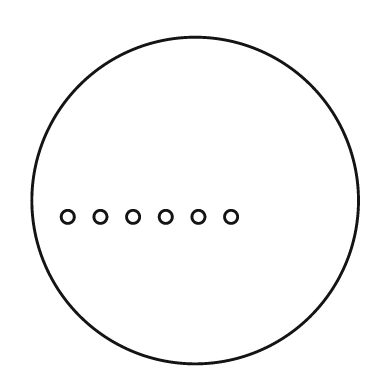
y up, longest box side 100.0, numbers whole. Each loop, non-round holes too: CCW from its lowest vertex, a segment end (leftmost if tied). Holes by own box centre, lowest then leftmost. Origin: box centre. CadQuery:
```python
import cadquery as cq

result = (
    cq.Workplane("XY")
    .moveTo(0.0, 0.0)
    .circle(50.0)
    .moveTo(-39.0, -5.0)
    .circle(2.0)
    .moveTo(-29.0, -5.0)
    .circle(2.0)
    .moveTo(-19.0, -5.0)
    .circle(2.0)
    .moveTo(-9.0, -5.0)
    .circle(2.0)
    .moveTo(1.0, -5.0)
    .circle(2.0)
    .moveTo(11.0, -5.0)
    .circle(2.0)
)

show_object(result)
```